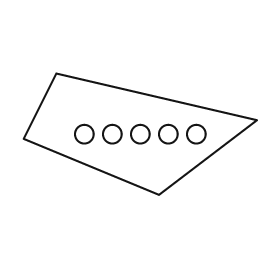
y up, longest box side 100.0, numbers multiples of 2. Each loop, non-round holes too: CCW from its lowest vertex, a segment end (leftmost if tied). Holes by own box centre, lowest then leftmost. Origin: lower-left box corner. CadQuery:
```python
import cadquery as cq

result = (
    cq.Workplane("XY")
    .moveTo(58.0, 0.0)
    .lineTo(100.0, 32.0)
    .lineTo(14.0, 52.0)
    .lineTo(0.0, 24.0)
    .close()
    .moveTo(26.0, 26.0)
    .circle(4.0)
    .moveTo(38.0, 26.0)
    .circle(4.0)
    .moveTo(50.0, 26.0)
    .circle(4.0)
    .moveTo(62.0, 26.0)
    .circle(4.0)
    .moveTo(74.0, 26.0)
    .circle(4.0)
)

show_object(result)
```